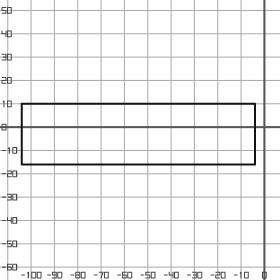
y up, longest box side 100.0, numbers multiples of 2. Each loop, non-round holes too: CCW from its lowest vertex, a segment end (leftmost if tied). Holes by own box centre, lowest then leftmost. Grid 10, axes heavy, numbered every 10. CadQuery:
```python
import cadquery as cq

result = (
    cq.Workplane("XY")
    .moveTo(-104.0, -16.0)
    .lineTo(-4.0, -16.0)
    .lineTo(-4.0, 10.0)
    .lineTo(-104.0, 10.0)
    .close()
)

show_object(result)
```